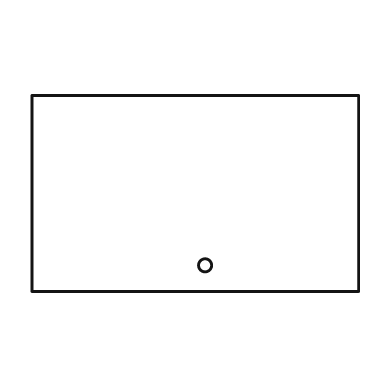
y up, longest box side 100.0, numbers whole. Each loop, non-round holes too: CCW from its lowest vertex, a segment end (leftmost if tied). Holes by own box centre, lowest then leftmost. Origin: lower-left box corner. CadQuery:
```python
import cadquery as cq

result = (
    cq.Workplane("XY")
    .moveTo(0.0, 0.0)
    .lineTo(100.0, 0.0)
    .lineTo(100.0, 60.0)
    .lineTo(0.0, 60.0)
    .close()
    .moveTo(53.0, 8.0)
    .circle(2.0)
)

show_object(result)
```